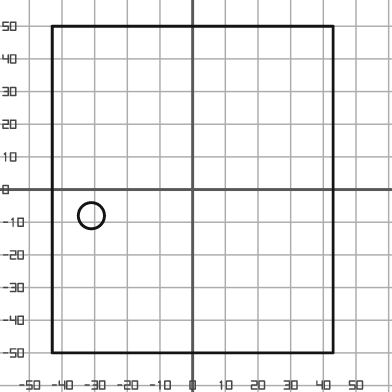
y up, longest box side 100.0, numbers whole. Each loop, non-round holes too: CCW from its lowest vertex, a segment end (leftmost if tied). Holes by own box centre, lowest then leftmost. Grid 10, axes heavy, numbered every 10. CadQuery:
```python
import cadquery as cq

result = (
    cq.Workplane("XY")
    .moveTo(-43.0, -50.0)
    .lineTo(43.0, -50.0)
    .lineTo(43.0, 50.0)
    .lineTo(-43.0, 50.0)
    .close()
    .moveTo(-31.0, -8.0)
    .circle(4.0)
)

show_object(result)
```